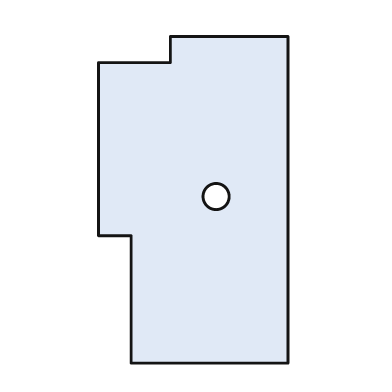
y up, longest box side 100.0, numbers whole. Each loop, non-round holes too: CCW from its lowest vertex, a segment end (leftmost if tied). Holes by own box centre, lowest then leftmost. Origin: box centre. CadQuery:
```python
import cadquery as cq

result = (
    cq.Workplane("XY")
    .moveTo(-19.0, -50.0)
    .lineTo(29.0, -50.0)
    .lineTo(29.0, 50.0)
    .lineTo(-7.0, 50.0)
    .lineTo(-7.0, 42.0)
    .lineTo(-29.0, 42.0)
    .lineTo(-29.0, -11.0)
    .lineTo(-19.0, -11.0)
    .close()
    .moveTo(7.0, 1.0)
    .circle(4.0)
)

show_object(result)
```